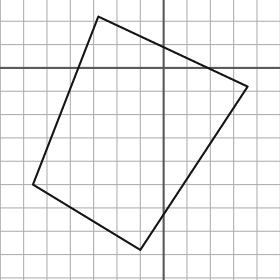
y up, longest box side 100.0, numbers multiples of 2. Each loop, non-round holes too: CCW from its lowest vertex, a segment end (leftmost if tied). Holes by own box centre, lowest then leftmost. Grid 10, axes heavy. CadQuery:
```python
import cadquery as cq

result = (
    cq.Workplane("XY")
    .moveTo(-10.0, -78.0)
    .lineTo(36.0, -8.0)
    .lineTo(-28.0, 22.0)
    .lineTo(-56.0, -50.0)
    .close()
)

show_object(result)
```